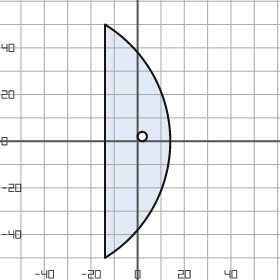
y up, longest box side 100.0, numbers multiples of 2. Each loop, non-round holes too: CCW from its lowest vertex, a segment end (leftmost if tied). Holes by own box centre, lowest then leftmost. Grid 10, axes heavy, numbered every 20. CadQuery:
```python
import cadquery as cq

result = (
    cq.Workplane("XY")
    .moveTo(-14.0, -50.0)
    .threePointArc((14.0, 0.0), (-14.0, 50.0))
    .close()
    .moveTo(2.0, 2.0)
    .circle(2.0)
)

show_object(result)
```